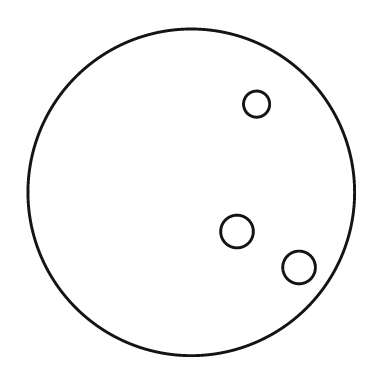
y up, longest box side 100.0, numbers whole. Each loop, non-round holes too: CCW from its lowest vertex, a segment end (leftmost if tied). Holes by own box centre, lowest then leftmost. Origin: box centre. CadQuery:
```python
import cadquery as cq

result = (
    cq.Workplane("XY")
    .moveTo(0.0, 0.0)
    .circle(50.0)
    .moveTo(33.0, -23.0)
    .circle(5.0)
    .moveTo(14.0, -12.0)
    .circle(5.0)
    .moveTo(20.0, 27.0)
    .circle(4.0)
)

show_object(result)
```